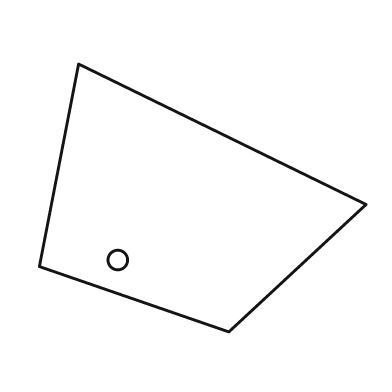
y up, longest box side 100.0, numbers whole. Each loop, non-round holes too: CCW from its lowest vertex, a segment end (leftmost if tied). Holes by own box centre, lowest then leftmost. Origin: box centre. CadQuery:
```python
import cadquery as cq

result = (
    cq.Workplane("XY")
    .moveTo(8.0, -41.0)
    .lineTo(50.0, -2.0)
    .lineTo(-38.0, 41.0)
    .lineTo(-50.0, -21.0)
    .close()
    .moveTo(-26.0, -19.0)
    .circle(3.0)
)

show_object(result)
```